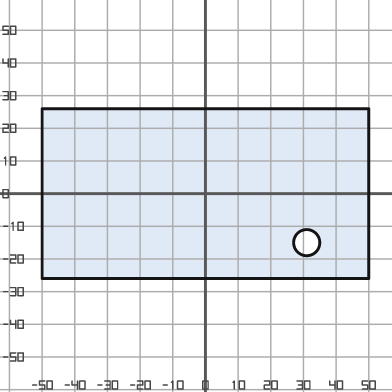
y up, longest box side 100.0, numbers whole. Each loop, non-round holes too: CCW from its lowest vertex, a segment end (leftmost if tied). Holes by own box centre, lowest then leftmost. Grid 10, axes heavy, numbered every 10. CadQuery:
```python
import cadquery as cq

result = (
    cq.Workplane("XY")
    .moveTo(-50.0, -26.0)
    .lineTo(50.0, -26.0)
    .lineTo(50.0, 26.0)
    .lineTo(-50.0, 26.0)
    .close()
    .moveTo(31.0, -15.0)
    .circle(4.0)
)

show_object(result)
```